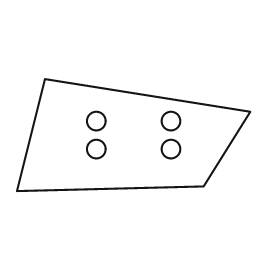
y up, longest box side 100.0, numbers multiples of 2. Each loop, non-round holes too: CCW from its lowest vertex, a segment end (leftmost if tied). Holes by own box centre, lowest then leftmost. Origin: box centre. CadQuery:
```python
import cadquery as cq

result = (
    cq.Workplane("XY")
    .moveTo(-50.0, -24.0)
    .lineTo(30.0, -22.0)
    .lineTo(50.0, 10.0)
    .lineTo(-38.0, 24.0)
    .close()
    .moveTo(-16.0, -6.0)
    .circle(4.0)
    .moveTo(16.0, -6.0)
    .circle(4.0)
    .moveTo(-16.0, 6.0)
    .circle(4.0)
    .moveTo(16.0, 6.0)
    .circle(4.0)
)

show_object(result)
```